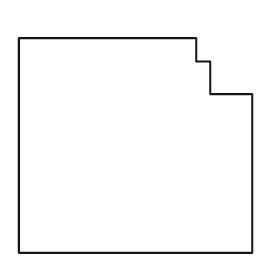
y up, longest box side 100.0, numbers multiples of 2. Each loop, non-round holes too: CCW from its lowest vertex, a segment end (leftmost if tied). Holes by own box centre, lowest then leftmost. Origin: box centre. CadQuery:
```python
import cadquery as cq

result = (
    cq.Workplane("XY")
    .moveTo(-50.0, -46.0)
    .lineTo(50.0, -46.0)
    .lineTo(50.0, 22.0)
    .lineTo(32.0, 22.0)
    .lineTo(32.0, 36.0)
    .lineTo(26.0, 36.0)
    .lineTo(26.0, 46.0)
    .lineTo(-50.0, 46.0)
    .close()
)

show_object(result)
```